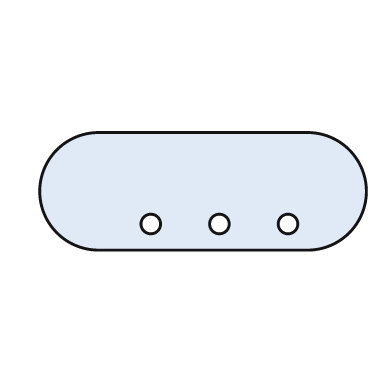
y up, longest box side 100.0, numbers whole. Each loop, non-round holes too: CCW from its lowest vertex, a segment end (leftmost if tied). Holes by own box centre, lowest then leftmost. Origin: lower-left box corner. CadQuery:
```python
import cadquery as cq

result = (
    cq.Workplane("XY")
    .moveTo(18.0, 0.0)
    .lineTo(82.0, 0.0)
    .threePointArc((100.0, 18.0), (82.0, 36.0))
    .lineTo(18.0, 36.0)
    .threePointArc((0.0, 18.0), (18.0, 0.0))
    .close()
    .moveTo(34.0, 8.0)
    .circle(3.0)
    .moveTo(55.0, 8.0)
    .circle(3.0)
    .moveTo(76.0, 8.0)
    .circle(3.0)
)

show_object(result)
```